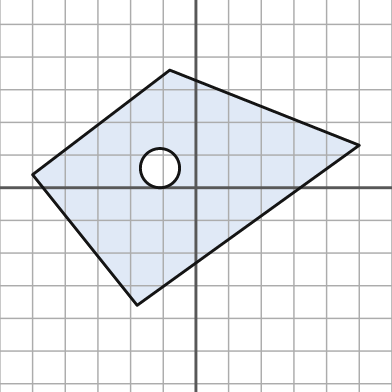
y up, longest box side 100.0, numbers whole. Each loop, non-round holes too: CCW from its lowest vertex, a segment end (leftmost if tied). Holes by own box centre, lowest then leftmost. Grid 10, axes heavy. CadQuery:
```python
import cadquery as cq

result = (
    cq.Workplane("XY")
    .moveTo(-18.0, -36.0)
    .lineTo(50.0, 13.0)
    .lineTo(-8.0, 36.0)
    .lineTo(-50.0, 4.0)
    .close()
    .moveTo(-11.0, 6.0)
    .circle(6.0)
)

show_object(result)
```